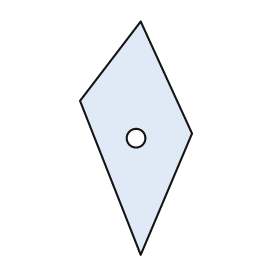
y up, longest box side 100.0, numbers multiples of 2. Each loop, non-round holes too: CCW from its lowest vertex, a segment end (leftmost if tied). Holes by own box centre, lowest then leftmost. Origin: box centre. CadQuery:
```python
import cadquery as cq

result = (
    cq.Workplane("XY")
    .moveTo(2.0, -50.0)
    .lineTo(24.0, 2.0)
    .lineTo(2.0, 50.0)
    .lineTo(-24.0, 16.0)
    .close()
    .moveTo(0.0, 0.0)
    .circle(4.0)
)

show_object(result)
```